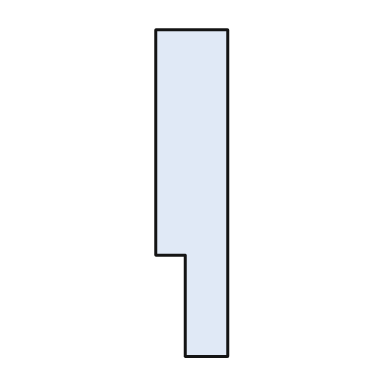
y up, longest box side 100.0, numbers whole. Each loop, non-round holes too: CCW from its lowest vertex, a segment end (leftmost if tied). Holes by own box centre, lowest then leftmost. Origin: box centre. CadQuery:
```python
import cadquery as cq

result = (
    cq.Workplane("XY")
    .moveTo(-2.0, -50.0)
    .lineTo(11.0, -50.0)
    .lineTo(11.0, 50.0)
    .lineTo(-11.0, 50.0)
    .lineTo(-11.0, -19.0)
    .lineTo(-2.0, -19.0)
    .close()
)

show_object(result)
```